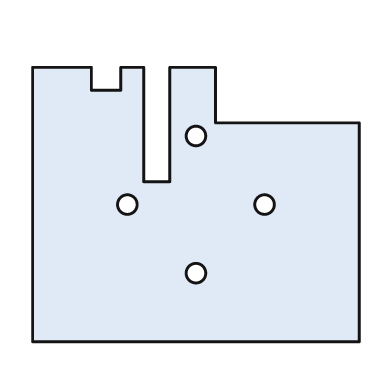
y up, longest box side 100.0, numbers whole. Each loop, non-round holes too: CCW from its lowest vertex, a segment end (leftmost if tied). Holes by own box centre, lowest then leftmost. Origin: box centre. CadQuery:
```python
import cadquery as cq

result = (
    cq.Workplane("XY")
    .moveTo(-50.0, -42.0)
    .lineTo(50.0, -42.0)
    .lineTo(50.0, 25.0)
    .lineTo(6.0, 25.0)
    .lineTo(6.0, 42.0)
    .lineTo(-8.0, 42.0)
    .lineTo(-8.0, 7.0)
    .lineTo(-16.0, 7.0)
    .lineTo(-16.0, 42.0)
    .lineTo(-23.0, 42.0)
    .lineTo(-23.0, 35.0)
    .lineTo(-32.0, 35.0)
    .lineTo(-32.0, 42.0)
    .lineTo(-50.0, 42.0)
    .close()
    .moveTo(0.0, -21.0)
    .circle(3.0)
    .moveTo(-21.0, 0.0)
    .circle(3.0)
    .moveTo(21.0, 0.0)
    .circle(3.0)
    .moveTo(0.0, 21.0)
    .circle(3.0)
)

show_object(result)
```